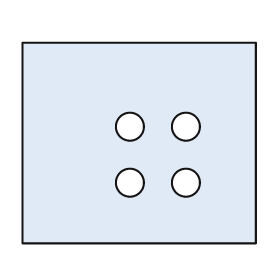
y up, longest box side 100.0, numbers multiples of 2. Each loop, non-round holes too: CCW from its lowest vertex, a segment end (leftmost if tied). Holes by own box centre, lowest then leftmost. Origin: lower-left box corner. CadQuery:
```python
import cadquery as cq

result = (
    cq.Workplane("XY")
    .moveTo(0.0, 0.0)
    .lineTo(100.0, 0.0)
    .lineTo(100.0, 86.0)
    .lineTo(0.0, 86.0)
    .close()
    .moveTo(46.0, 26.0)
    .circle(6.0)
    .moveTo(70.0, 26.0)
    .circle(6.0)
    .moveTo(46.0, 50.0)
    .circle(6.0)
    .moveTo(70.0, 50.0)
    .circle(6.0)
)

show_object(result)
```